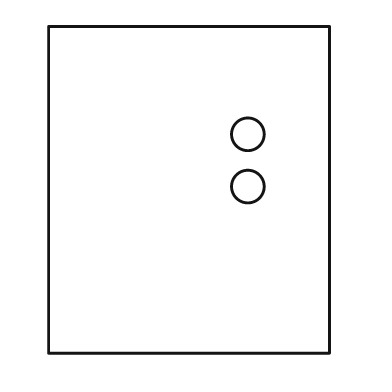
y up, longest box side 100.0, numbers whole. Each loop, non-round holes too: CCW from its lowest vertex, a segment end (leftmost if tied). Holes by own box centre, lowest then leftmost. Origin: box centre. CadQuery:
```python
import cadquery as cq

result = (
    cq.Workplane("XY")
    .moveTo(-43.0, -50.0)
    .lineTo(43.0, -50.0)
    .lineTo(43.0, 50.0)
    .lineTo(-43.0, 50.0)
    .close()
    .moveTo(18.0, 1.0)
    .circle(5.0)
    .moveTo(18.0, 17.0)
    .circle(5.0)
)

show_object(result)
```